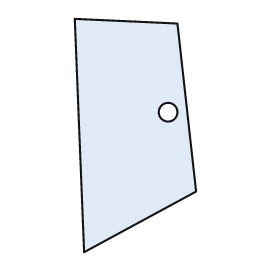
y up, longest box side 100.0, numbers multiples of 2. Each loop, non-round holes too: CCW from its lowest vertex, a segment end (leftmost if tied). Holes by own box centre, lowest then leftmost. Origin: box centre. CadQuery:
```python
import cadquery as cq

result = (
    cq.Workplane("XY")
    .moveTo(-22.0, -50.0)
    .lineTo(26.0, -24.0)
    .lineTo(18.0, 48.0)
    .lineTo(-26.0, 50.0)
    .close()
    .moveTo(14.0, 10.0)
    .circle(4.0)
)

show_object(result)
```